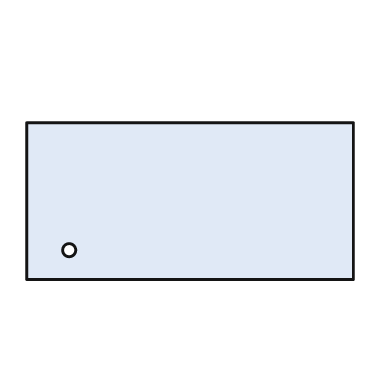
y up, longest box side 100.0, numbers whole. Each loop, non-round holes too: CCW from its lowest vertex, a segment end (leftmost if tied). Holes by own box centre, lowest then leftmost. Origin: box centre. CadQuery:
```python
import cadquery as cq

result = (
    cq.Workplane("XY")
    .moveTo(-50.0, -24.0)
    .lineTo(50.0, -24.0)
    .lineTo(50.0, 24.0)
    .lineTo(-50.0, 24.0)
    .close()
    .moveTo(-37.0, -15.0)
    .circle(2.0)
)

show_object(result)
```